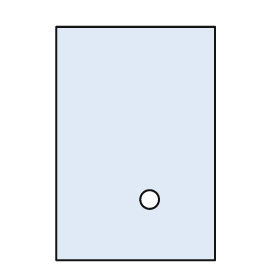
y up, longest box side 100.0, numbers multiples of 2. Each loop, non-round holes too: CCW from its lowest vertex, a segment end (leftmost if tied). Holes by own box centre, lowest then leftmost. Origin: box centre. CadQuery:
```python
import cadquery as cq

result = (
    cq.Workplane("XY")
    .moveTo(-34.0, -50.0)
    .lineTo(34.0, -50.0)
    .lineTo(34.0, 50.0)
    .lineTo(-34.0, 50.0)
    .close()
    .moveTo(6.0, -24.0)
    .circle(4.0)
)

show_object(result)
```